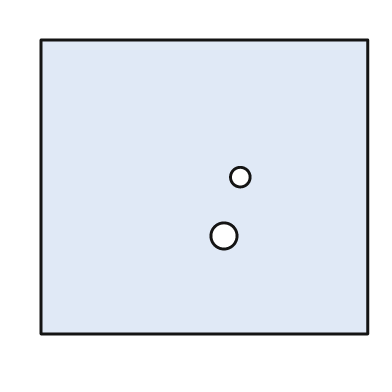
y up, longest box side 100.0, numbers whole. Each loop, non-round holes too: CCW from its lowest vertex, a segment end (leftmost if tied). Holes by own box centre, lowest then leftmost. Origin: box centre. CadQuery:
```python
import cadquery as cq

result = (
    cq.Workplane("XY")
    .moveTo(-50.0, -45.0)
    .lineTo(50.0, -45.0)
    .lineTo(50.0, 45.0)
    .lineTo(-50.0, 45.0)
    .close()
    .moveTo(6.0, -15.0)
    .circle(4.0)
    .moveTo(11.0, 3.0)
    .circle(3.0)
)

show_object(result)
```